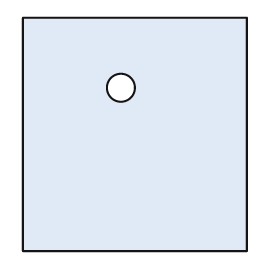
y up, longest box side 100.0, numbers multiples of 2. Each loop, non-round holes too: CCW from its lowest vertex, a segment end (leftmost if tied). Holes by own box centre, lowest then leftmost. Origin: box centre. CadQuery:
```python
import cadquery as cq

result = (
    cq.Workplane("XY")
    .moveTo(-48.0, -50.0)
    .lineTo(48.0, -50.0)
    .lineTo(48.0, 50.0)
    .lineTo(-48.0, 50.0)
    .close()
    .moveTo(-6.0, 20.0)
    .circle(6.0)
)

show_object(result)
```